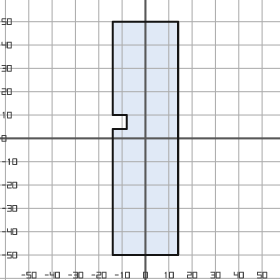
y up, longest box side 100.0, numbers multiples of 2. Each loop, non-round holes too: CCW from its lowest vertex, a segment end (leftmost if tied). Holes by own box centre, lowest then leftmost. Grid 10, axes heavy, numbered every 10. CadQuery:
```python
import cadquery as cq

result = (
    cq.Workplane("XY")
    .moveTo(-14.0, -50.0)
    .lineTo(14.0, -50.0)
    .lineTo(14.0, 50.0)
    .lineTo(-14.0, 50.0)
    .lineTo(-14.0, 10.0)
    .lineTo(-8.0, 10.0)
    .lineTo(-8.0, 4.0)
    .lineTo(-14.0, 4.0)
    .close()
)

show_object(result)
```